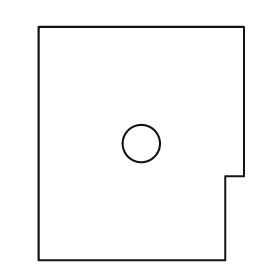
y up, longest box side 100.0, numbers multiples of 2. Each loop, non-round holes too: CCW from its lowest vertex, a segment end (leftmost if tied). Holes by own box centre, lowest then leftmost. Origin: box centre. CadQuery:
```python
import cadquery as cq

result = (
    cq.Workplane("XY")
    .moveTo(-44.0, -50.0)
    .lineTo(36.0, -50.0)
    .lineTo(36.0, -14.0)
    .lineTo(44.0, -14.0)
    .lineTo(44.0, 50.0)
    .lineTo(-44.0, 50.0)
    .close()
    .moveTo(0.0, 0.0)
    .circle(8.0)
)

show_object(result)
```